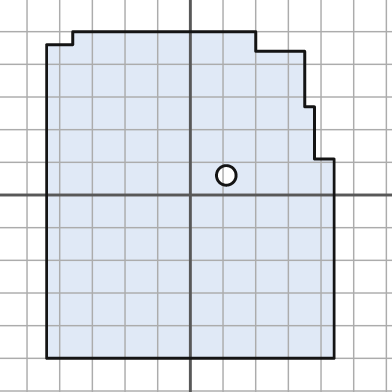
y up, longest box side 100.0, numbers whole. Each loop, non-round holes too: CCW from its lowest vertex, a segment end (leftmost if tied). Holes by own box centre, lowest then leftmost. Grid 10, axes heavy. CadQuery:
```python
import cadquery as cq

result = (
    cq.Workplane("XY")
    .moveTo(-44.0, -50.0)
    .lineTo(44.0, -50.0)
    .lineTo(44.0, 11.0)
    .lineTo(38.0, 11.0)
    .lineTo(38.0, 27.0)
    .lineTo(35.0, 27.0)
    .lineTo(35.0, 44.0)
    .lineTo(20.0, 44.0)
    .lineTo(20.0, 50.0)
    .lineTo(-36.0, 50.0)
    .lineTo(-36.0, 46.0)
    .lineTo(-44.0, 46.0)
    .close()
    .moveTo(11.0, 6.0)
    .circle(3.0)
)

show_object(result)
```